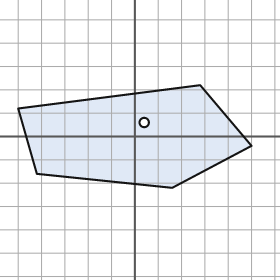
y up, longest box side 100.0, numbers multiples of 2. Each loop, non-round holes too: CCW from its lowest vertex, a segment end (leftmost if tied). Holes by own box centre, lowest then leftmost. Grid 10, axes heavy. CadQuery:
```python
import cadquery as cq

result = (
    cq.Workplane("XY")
    .moveTo(16.0, -22.0)
    .lineTo(50.0, -4.0)
    .lineTo(28.0, 22.0)
    .lineTo(-50.0, 12.0)
    .lineTo(-42.0, -16.0)
    .close()
    .moveTo(4.0, 6.0)
    .circle(2.0)
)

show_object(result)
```